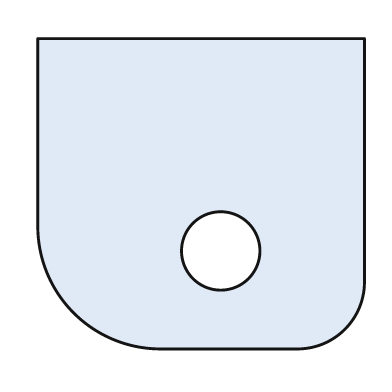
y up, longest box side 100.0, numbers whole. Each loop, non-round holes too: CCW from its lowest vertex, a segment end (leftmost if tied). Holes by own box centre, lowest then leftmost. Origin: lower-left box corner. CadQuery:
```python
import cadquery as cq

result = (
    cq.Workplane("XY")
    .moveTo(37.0, 0.0)
    .lineTo(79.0, 0.0)
    .threePointArc((94.0, 6.0), (100.0, 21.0))
    .lineTo(100.0, 95.0)
    .lineTo(0.0, 95.0)
    .lineTo(0.0, 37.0)
    .threePointArc((11.0, 11.0), (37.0, 0.0))
    .close()
    .moveTo(56.0, 30.0)
    .circle(12.0)
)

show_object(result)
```